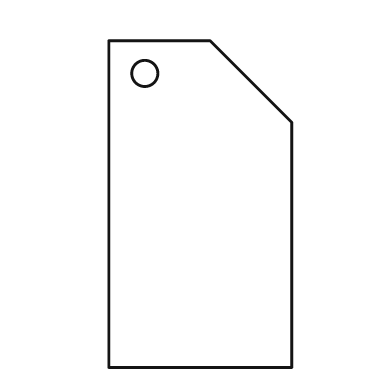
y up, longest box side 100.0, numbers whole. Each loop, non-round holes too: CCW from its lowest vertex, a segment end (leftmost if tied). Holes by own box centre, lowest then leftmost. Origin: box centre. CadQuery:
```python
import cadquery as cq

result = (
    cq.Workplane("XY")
    .moveTo(-28.0, -50.0)
    .lineTo(28.0, -50.0)
    .lineTo(28.0, 25.0)
    .lineTo(3.0, 50.0)
    .lineTo(-28.0, 50.0)
    .close()
    .moveTo(-17.0, 40.0)
    .circle(4.0)
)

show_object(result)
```